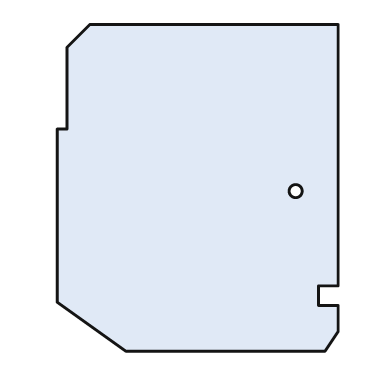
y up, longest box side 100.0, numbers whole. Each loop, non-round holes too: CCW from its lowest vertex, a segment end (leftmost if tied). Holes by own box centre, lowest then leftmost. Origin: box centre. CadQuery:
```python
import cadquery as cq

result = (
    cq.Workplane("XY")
    .moveTo(-22.0, -50.0)
    .lineTo(39.0, -50.0)
    .lineTo(43.0, -44.0)
    .lineTo(43.0, -36.0)
    .lineTo(37.0, -36.0)
    .lineTo(37.0, -30.0)
    .lineTo(43.0, -30.0)
    .lineTo(43.0, 50.0)
    .lineTo(-33.0, 50.0)
    .lineTo(-40.0, 43.0)
    .lineTo(-40.0, 18.0)
    .lineTo(-43.0, 18.0)
    .lineTo(-43.0, -35.0)
    .close()
    .moveTo(30.0, -1.0)
    .circle(2.0)
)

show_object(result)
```